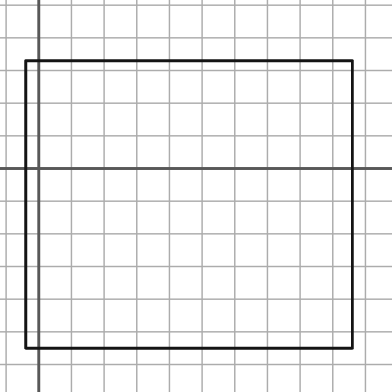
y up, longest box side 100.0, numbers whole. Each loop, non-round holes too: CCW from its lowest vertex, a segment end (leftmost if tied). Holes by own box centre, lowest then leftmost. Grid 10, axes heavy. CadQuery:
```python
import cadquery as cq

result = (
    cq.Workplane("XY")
    .moveTo(-4.0, -55.0)
    .lineTo(96.0, -55.0)
    .lineTo(96.0, 33.0)
    .lineTo(-4.0, 33.0)
    .close()
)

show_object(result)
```